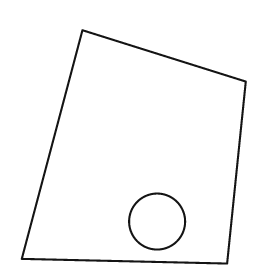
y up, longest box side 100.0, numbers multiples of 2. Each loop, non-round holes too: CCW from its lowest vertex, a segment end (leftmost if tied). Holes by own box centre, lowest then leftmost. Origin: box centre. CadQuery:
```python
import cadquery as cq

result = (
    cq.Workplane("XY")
    .moveTo(40.0, -50.0)
    .lineTo(48.0, 28.0)
    .lineTo(-22.0, 50.0)
    .lineTo(-48.0, -48.0)
    .close()
    .moveTo(10.0, -32.0)
    .circle(12.0)
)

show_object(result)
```